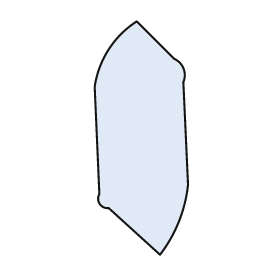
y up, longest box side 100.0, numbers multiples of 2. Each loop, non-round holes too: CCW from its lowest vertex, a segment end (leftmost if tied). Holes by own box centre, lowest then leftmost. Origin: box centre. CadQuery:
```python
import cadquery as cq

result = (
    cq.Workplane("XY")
    .moveTo(8.0, -50.0)
    .threePointArc((16.0, -36.0), (20.0, -20.0))
    .lineTo(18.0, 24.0)
    .threePointArc((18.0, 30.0), (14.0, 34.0))
    .lineTo(-2.0, 50.0)
    .threePointArc((-14.0, 38.0), (-20.0, 22.0))
    .lineTo(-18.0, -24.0)
    .threePointArc((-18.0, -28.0), (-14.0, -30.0))
    .close()
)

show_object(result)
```